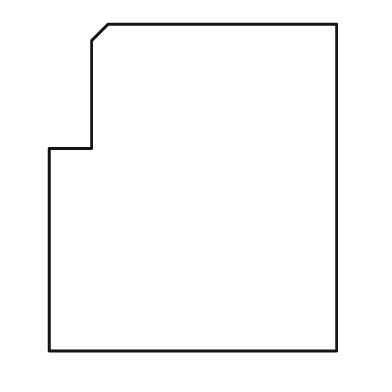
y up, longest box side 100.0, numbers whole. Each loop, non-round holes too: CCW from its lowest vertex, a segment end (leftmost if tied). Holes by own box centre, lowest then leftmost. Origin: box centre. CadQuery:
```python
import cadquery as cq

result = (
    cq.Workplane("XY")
    .moveTo(-44.0, -50.0)
    .lineTo(44.0, -50.0)
    .lineTo(44.0, 50.0)
    .lineTo(-26.0, 50.0)
    .lineTo(-31.0, 45.0)
    .lineTo(-31.0, 12.0)
    .lineTo(-44.0, 12.0)
    .close()
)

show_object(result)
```